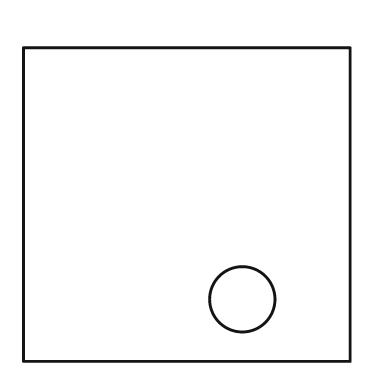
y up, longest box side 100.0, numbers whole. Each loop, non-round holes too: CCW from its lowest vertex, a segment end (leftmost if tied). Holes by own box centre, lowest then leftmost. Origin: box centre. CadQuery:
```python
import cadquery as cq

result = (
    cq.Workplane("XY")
    .moveTo(-50.0, -48.0)
    .lineTo(50.0, -48.0)
    .lineTo(50.0, 48.0)
    .lineTo(-50.0, 48.0)
    .close()
    .moveTo(17.0, -29.0)
    .circle(10.0)
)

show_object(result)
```